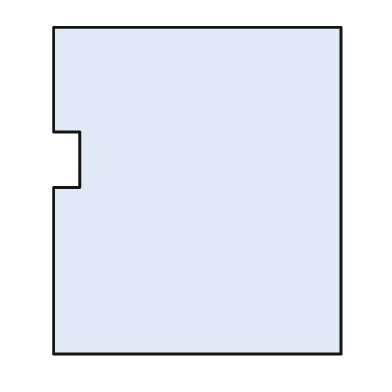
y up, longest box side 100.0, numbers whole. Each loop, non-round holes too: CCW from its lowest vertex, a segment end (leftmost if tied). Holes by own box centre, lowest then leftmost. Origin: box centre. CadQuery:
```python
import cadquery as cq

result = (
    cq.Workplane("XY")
    .moveTo(-44.0, -50.0)
    .lineTo(44.0, -50.0)
    .lineTo(44.0, 50.0)
    .lineTo(-44.0, 50.0)
    .lineTo(-44.0, 18.0)
    .lineTo(-36.0, 18.0)
    .lineTo(-36.0, 1.0)
    .lineTo(-44.0, 1.0)
    .close()
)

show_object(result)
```